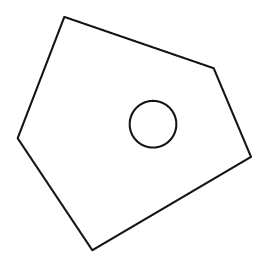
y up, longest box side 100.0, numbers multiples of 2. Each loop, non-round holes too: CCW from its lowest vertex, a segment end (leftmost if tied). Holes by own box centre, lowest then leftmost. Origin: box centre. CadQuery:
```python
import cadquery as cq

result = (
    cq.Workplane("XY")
    .moveTo(-18.0, -50.0)
    .lineTo(50.0, -10.0)
    .lineTo(34.0, 28.0)
    .lineTo(-30.0, 50.0)
    .lineTo(-50.0, -2.0)
    .close()
    .moveTo(8.0, 4.0)
    .circle(10.0)
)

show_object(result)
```